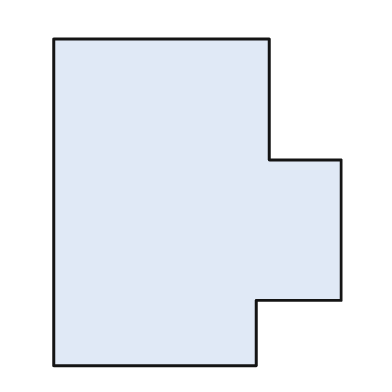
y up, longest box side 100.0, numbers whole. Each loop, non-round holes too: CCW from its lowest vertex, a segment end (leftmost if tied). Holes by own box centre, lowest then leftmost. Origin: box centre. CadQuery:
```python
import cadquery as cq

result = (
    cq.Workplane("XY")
    .moveTo(-44.0, -50.0)
    .lineTo(18.0, -50.0)
    .lineTo(18.0, -30.0)
    .lineTo(44.0, -30.0)
    .lineTo(44.0, 13.0)
    .lineTo(22.0, 13.0)
    .lineTo(22.0, 50.0)
    .lineTo(-44.0, 50.0)
    .close()
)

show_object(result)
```